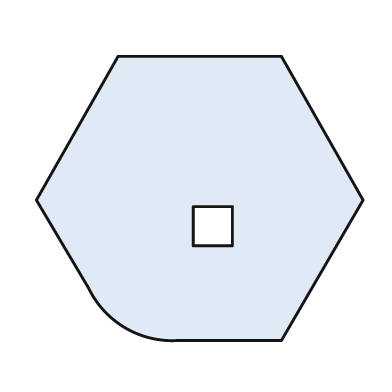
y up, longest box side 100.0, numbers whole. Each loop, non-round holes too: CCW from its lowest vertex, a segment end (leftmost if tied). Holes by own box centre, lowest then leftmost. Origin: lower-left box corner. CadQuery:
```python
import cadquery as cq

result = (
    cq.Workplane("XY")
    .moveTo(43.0, 0.0)
    .lineTo(75.0, 0.0)
    .lineTo(100.0, 43.0)
    .lineTo(75.0, 87.0)
    .lineTo(25.0, 87.0)
    .lineTo(0.0, 43.0)
    .lineTo(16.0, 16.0)
    .threePointArc((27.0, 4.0), (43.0, 0.0))
    .close()
    .moveTo(48.0, 29.0)
    .lineTo(60.0, 29.0)
    .lineTo(60.0, 41.0)
    .lineTo(48.0, 41.0)
    .close()
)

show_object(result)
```